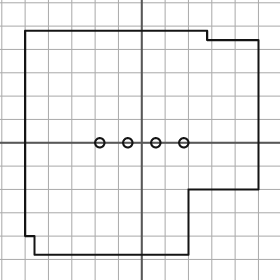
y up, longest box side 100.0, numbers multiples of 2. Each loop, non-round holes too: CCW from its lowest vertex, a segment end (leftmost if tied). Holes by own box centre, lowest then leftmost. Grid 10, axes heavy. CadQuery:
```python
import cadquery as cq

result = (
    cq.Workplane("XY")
    .moveTo(-46.0, -48.0)
    .lineTo(20.0, -48.0)
    .lineTo(20.0, -20.0)
    .lineTo(50.0, -20.0)
    .lineTo(50.0, 44.0)
    .lineTo(28.0, 44.0)
    .lineTo(28.0, 48.0)
    .lineTo(-50.0, 48.0)
    .lineTo(-50.0, -40.0)
    .lineTo(-46.0, -40.0)
    .close()
    .moveTo(-18.0, 0.0)
    .circle(2.0)
    .moveTo(-6.0, 0.0)
    .circle(2.0)
    .moveTo(6.0, 0.0)
    .circle(2.0)
    .moveTo(18.0, 0.0)
    .circle(2.0)
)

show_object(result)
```